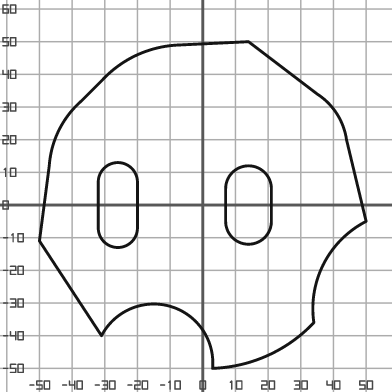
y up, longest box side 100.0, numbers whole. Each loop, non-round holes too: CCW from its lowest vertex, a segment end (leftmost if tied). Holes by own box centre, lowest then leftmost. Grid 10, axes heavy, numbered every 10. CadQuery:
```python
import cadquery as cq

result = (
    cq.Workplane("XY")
    .moveTo(3.0, -50.0)
    .threePointArc((20.0, -46.0), (34.0, -36.0))
    .threePointArc((37.0, -18.0), (50.0, -5.0))
    .lineTo(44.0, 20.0)
    .threePointArc((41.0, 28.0), (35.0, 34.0))
    .lineTo(14.0, 50.0)
    .lineTo(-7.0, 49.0)
    .threePointArc((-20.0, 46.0), (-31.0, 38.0))
    .lineTo(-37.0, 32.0)
    .threePointArc((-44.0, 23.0), (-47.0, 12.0))
    .lineTo(-50.0, -11.0)
    .lineTo(-31.0, -40.0)
    .threePointArc((-10.0, -31.0), (3.0, -50.0))
    .close()
    .moveTo(-32.0, -7.0)
    .threePointArc((-26.0, -13.0), (-20.0, -7.0))
    .lineTo(-20.0, 7.0)
    .threePointArc((-26.0, 13.0), (-32.0, 7.0))
    .close()
    .moveTo(7.0, -5.0)
    .threePointArc((14.0, -12.0), (21.0, -5.0))
    .lineTo(21.0, 5.0)
    .threePointArc((14.0, 12.0), (7.0, 5.0))
    .close()
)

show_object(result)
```